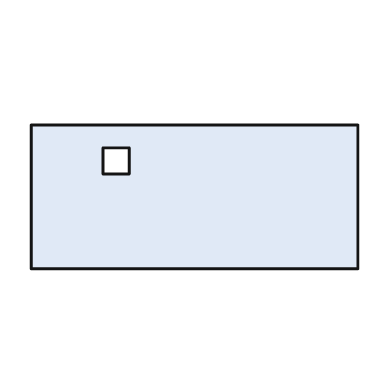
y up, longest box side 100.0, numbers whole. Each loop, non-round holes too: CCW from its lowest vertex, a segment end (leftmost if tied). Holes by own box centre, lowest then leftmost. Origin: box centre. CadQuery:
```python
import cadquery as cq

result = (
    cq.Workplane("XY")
    .moveTo(-50.0, -22.0)
    .lineTo(50.0, -22.0)
    .lineTo(50.0, 22.0)
    .lineTo(-50.0, 22.0)
    .close()
    .moveTo(-28.0, 7.0)
    .lineTo(-20.0, 7.0)
    .lineTo(-20.0, 15.0)
    .lineTo(-28.0, 15.0)
    .close()
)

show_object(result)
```